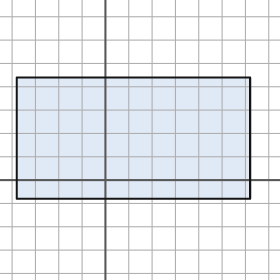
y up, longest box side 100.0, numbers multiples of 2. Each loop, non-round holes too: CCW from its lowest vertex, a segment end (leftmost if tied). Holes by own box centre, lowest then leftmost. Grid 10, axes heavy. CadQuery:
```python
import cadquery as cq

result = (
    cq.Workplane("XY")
    .moveTo(-38.0, -8.0)
    .lineTo(62.0, -8.0)
    .lineTo(62.0, 44.0)
    .lineTo(-38.0, 44.0)
    .close()
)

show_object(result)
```